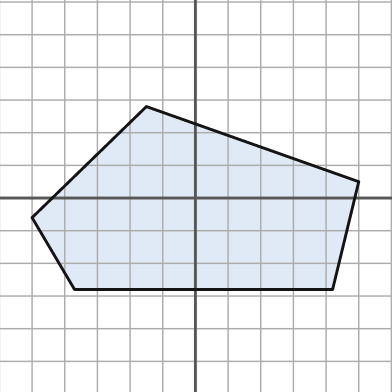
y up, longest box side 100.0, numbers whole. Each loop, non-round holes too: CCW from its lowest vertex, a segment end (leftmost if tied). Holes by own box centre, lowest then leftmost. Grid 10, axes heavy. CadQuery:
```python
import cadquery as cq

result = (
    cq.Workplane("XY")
    .moveTo(-37.0, -28.0)
    .lineTo(42.0, -28.0)
    .lineTo(50.0, 5.0)
    .lineTo(-15.0, 28.0)
    .lineTo(-50.0, -6.0)
    .close()
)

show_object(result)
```